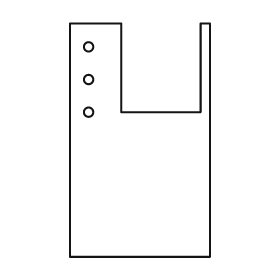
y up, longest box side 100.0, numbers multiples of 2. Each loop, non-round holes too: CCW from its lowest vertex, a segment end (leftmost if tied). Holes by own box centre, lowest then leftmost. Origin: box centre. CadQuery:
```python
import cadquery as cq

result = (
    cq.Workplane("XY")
    .moveTo(-30.0, -50.0)
    .lineTo(30.0, -50.0)
    .lineTo(30.0, 50.0)
    .lineTo(26.0, 50.0)
    .lineTo(26.0, 12.0)
    .lineTo(-8.0, 12.0)
    .lineTo(-8.0, 50.0)
    .lineTo(-30.0, 50.0)
    .close()
    .moveTo(-22.0, 12.0)
    .circle(2.0)
    .moveTo(-22.0, 26.0)
    .circle(2.0)
    .moveTo(-22.0, 40.0)
    .circle(2.0)
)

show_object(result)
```